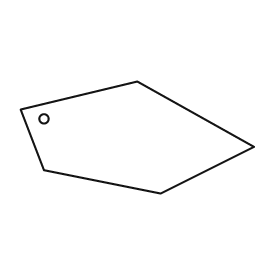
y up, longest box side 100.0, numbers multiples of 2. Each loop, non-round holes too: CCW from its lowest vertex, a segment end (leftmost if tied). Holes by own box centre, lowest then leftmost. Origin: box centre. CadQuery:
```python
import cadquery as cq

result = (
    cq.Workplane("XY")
    .moveTo(10.0, -24.0)
    .lineTo(50.0, -4.0)
    .lineTo(0.0, 24.0)
    .lineTo(-50.0, 12.0)
    .lineTo(-40.0, -14.0)
    .close()
    .moveTo(-40.0, 8.0)
    .circle(2.0)
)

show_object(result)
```